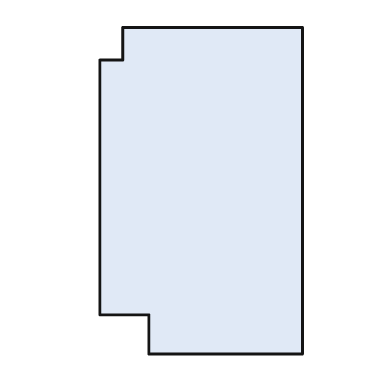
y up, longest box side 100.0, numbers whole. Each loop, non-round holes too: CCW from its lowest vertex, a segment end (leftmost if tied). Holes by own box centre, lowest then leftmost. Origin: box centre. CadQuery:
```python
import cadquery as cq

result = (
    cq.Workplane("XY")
    .moveTo(-16.0, -50.0)
    .lineTo(31.0, -50.0)
    .lineTo(31.0, 50.0)
    .lineTo(-24.0, 50.0)
    .lineTo(-24.0, 40.0)
    .lineTo(-31.0, 40.0)
    .lineTo(-31.0, -38.0)
    .lineTo(-16.0, -38.0)
    .close()
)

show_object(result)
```